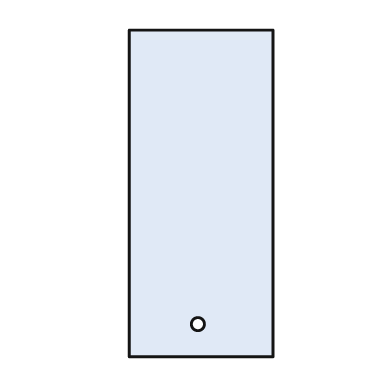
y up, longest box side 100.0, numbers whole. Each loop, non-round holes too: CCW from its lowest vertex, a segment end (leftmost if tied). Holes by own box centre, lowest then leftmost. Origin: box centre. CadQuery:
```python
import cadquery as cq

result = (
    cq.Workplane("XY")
    .moveTo(-22.0, -50.0)
    .lineTo(22.0, -50.0)
    .lineTo(22.0, 50.0)
    .lineTo(-22.0, 50.0)
    .close()
    .moveTo(-1.0, -40.0)
    .circle(2.0)
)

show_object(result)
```